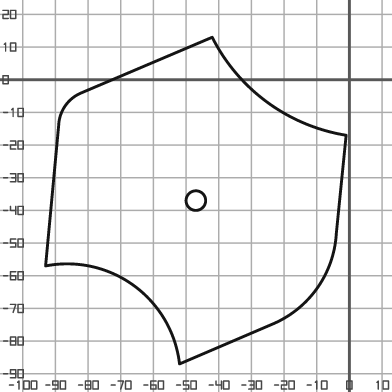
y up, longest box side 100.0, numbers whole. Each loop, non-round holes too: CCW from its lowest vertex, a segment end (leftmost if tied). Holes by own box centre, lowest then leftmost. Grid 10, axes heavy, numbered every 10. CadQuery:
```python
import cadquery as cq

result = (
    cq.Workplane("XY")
    .moveTo(-52.0, -87.0)
    .lineTo(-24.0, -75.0)
    .threePointArc((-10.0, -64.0), (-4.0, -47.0))
    .lineTo(-1.0, -17.0)
    .threePointArc((-25.0, -7.0), (-42.0, 13.0))
    .lineTo(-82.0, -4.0)
    .threePointArc((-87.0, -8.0), (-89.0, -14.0))
    .lineTo(-93.0, -57.0)
    .threePointArc((-66.0, -63.0), (-52.0, -87.0))
    .close()
    .moveTo(-47.0, -37.0)
    .circle(3.0)
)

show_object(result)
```